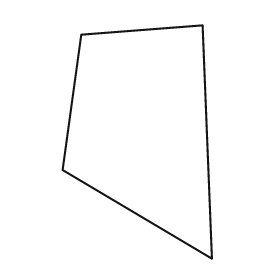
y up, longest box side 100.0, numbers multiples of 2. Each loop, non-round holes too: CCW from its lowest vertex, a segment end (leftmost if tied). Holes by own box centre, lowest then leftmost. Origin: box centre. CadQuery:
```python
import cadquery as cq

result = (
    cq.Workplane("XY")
    .moveTo(32.0, -50.0)
    .lineTo(28.0, 50.0)
    .lineTo(-24.0, 46.0)
    .lineTo(-32.0, -12.0)
    .close()
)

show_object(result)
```